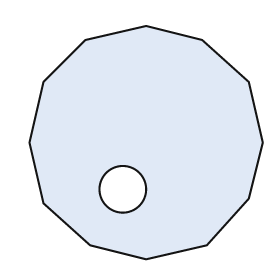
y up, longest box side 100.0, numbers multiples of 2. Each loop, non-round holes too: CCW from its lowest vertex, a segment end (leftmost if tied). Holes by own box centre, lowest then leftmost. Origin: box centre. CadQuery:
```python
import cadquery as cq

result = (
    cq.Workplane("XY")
    .moveTo(0.0, -50.0)
    .lineTo(26.0, -44.0)
    .lineTo(44.0, -24.0)
    .lineTo(50.0, 0.0)
    .lineTo(44.0, 26.0)
    .lineTo(24.0, 44.0)
    .lineTo(0.0, 50.0)
    .lineTo(-26.0, 44.0)
    .lineTo(-44.0, 26.0)
    .lineTo(-50.0, 0.0)
    .lineTo(-44.0, -26.0)
    .lineTo(-24.0, -44.0)
    .close()
    .moveTo(-10.0, -20.0)
    .circle(10.0)
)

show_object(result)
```